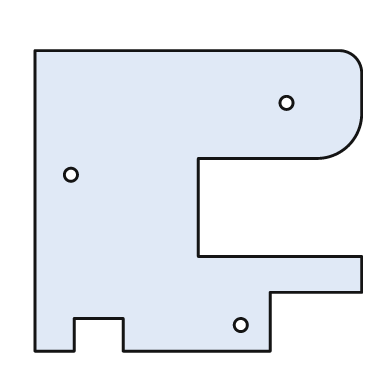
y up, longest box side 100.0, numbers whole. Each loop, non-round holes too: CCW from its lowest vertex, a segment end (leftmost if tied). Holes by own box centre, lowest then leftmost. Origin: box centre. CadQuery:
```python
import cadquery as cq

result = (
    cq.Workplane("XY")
    .moveTo(-50.0, -46.0)
    .lineTo(-38.0, -46.0)
    .lineTo(-38.0, -36.0)
    .lineTo(-23.0, -36.0)
    .lineTo(-23.0, -46.0)
    .lineTo(22.0, -46.0)
    .lineTo(22.0, -28.0)
    .lineTo(50.0, -28.0)
    .lineTo(50.0, -17.0)
    .lineTo(0.0, -17.0)
    .lineTo(0.0, 13.0)
    .lineTo(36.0, 13.0)
    .threePointArc((46.0, 17.0), (50.0, 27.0))
    .lineTo(50.0, 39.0)
    .threePointArc((48.0, 44.0), (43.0, 46.0))
    .lineTo(-50.0, 46.0)
    .close()
    .moveTo(13.0, -38.0)
    .circle(2.0)
    .moveTo(-39.0, 8.0)
    .circle(2.0)
    .moveTo(27.0, 30.0)
    .circle(2.0)
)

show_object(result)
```